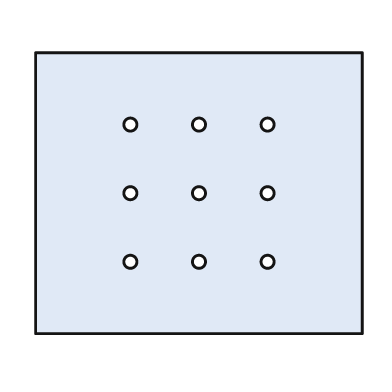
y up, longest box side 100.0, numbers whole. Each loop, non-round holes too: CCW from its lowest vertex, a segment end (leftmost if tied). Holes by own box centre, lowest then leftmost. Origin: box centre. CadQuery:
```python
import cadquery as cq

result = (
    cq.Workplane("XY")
    .moveTo(-50.0, -43.0)
    .lineTo(50.0, -43.0)
    .lineTo(50.0, 43.0)
    .lineTo(-50.0, 43.0)
    .close()
    .moveTo(-21.0, -21.0)
    .circle(2.0)
    .moveTo(0.0, -21.0)
    .circle(2.0)
    .moveTo(21.0, -21.0)
    .circle(2.0)
    .moveTo(-21.0, 0.0)
    .circle(2.0)
    .moveTo(0.0, 0.0)
    .circle(2.0)
    .moveTo(21.0, 0.0)
    .circle(2.0)
    .moveTo(-21.0, 21.0)
    .circle(2.0)
    .moveTo(0.0, 21.0)
    .circle(2.0)
    .moveTo(21.0, 21.0)
    .circle(2.0)
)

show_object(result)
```